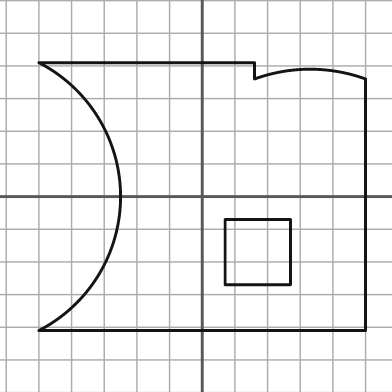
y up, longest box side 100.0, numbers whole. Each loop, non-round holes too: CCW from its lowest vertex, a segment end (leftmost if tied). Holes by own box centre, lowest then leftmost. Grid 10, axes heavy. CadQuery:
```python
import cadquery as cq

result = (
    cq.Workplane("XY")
    .moveTo(-50.0, -41.0)
    .lineTo(50.0, -41.0)
    .lineTo(50.0, 36.0)
    .threePointArc((33.0, 39.0), (16.0, 36.0))
    .lineTo(16.0, 41.0)
    .lineTo(-50.0, 41.0)
    .threePointArc((-25.0, 0.0), (-50.0, -41.0))
    .close()
    .moveTo(7.0, -27.0)
    .lineTo(27.0, -27.0)
    .lineTo(27.0, -7.0)
    .lineTo(7.0, -7.0)
    .close()
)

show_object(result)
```